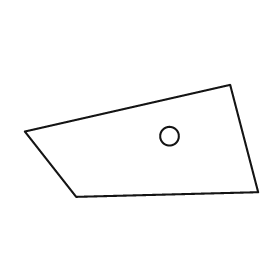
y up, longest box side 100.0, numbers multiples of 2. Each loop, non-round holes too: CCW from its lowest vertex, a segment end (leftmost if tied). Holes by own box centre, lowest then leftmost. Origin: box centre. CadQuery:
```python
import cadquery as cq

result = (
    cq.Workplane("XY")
    .moveTo(-28.0, -24.0)
    .lineTo(50.0, -22.0)
    .lineTo(38.0, 24.0)
    .lineTo(-50.0, 4.0)
    .close()
    .moveTo(12.0, 2.0)
    .circle(4.0)
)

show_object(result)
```